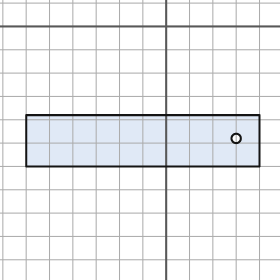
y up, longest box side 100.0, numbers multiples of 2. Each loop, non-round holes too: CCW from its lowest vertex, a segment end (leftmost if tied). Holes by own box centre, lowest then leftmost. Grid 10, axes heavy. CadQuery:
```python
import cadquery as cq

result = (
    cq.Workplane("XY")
    .moveTo(-60.0, -60.0)
    .lineTo(40.0, -60.0)
    .lineTo(40.0, -38.0)
    .lineTo(-60.0, -38.0)
    .close()
    .moveTo(30.0, -48.0)
    .circle(2.0)
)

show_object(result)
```